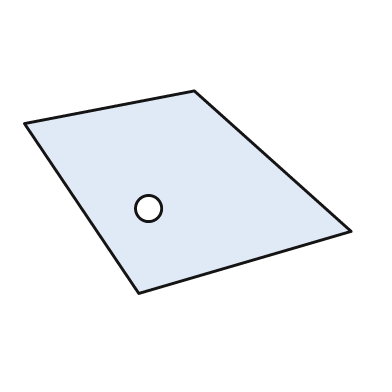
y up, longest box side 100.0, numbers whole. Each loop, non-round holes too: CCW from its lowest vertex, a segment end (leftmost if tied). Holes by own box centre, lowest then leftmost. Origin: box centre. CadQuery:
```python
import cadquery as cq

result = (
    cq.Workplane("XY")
    .moveTo(-15.0, -31.0)
    .lineTo(50.0, -12.0)
    .lineTo(2.0, 31.0)
    .lineTo(-50.0, 21.0)
    .close()
    .moveTo(-12.0, -5.0)
    .circle(4.0)
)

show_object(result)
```